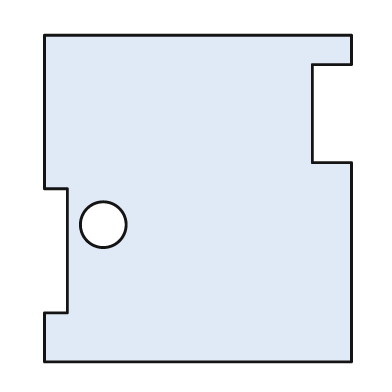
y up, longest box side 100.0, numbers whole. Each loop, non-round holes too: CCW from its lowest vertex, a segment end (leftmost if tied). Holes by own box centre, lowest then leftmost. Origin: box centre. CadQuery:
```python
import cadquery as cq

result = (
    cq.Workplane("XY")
    .moveTo(-47.0, -50.0)
    .lineTo(47.0, -50.0)
    .lineTo(47.0, 11.0)
    .lineTo(35.0, 11.0)
    .lineTo(35.0, 41.0)
    .lineTo(47.0, 41.0)
    .lineTo(47.0, 50.0)
    .lineTo(-47.0, 50.0)
    .lineTo(-47.0, 3.0)
    .lineTo(-40.0, 3.0)
    .lineTo(-40.0, -35.0)
    .lineTo(-47.0, -35.0)
    .close()
    .moveTo(-29.0, -8.0)
    .circle(7.0)
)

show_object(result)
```